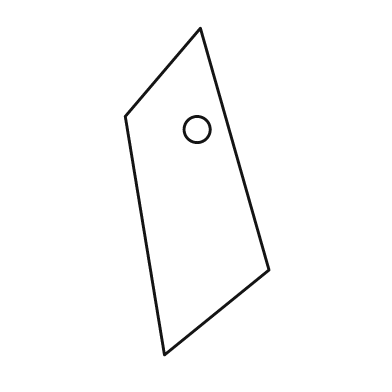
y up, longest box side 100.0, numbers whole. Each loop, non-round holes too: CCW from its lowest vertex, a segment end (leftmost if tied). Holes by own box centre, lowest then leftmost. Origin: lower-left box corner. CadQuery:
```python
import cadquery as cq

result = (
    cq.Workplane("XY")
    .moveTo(12.0, 0.0)
    .lineTo(44.0, 26.0)
    .lineTo(23.0, 100.0)
    .lineTo(0.0, 73.0)
    .close()
    .moveTo(22.0, 69.0)
    .circle(4.0)
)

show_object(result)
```